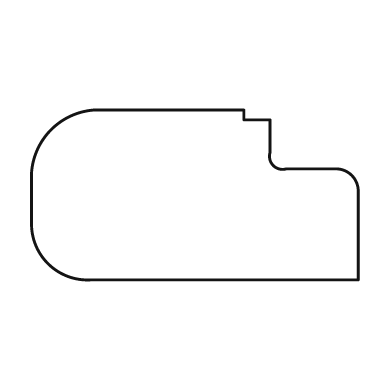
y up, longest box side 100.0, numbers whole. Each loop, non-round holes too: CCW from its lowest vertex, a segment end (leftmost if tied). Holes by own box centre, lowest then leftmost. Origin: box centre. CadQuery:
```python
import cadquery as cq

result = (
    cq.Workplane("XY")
    .moveTo(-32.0, -26.0)
    .lineTo(50.0, -26.0)
    .lineTo(50.0, 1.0)
    .threePointArc((48.0, 6.0), (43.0, 8.0))
    .lineTo(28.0, 8.0)
    .threePointArc((24.0, 9.0), (23.0, 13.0))
    .lineTo(23.0, 23.0)
    .lineTo(15.0, 23.0)
    .lineTo(15.0, 26.0)
    .lineTo(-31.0, 26.0)
    .threePointArc((-44.0, 20.0), (-50.0, 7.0))
    .lineTo(-50.0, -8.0)
    .threePointArc((-45.0, -21.0), (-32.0, -26.0))
    .close()
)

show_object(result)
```